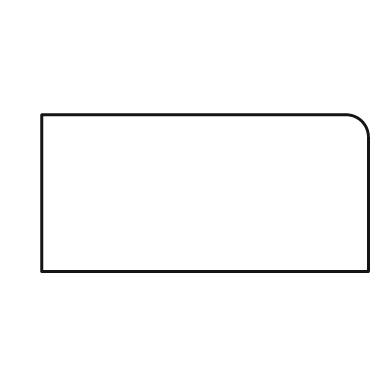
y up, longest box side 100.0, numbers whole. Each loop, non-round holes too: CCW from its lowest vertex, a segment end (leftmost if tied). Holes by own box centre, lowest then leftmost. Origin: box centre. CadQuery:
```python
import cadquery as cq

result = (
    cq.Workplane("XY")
    .moveTo(-50.0, -24.0)
    .lineTo(50.0, -24.0)
    .lineTo(50.0, 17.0)
    .threePointArc((48.0, 22.0), (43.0, 24.0))
    .lineTo(-50.0, 24.0)
    .close()
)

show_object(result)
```